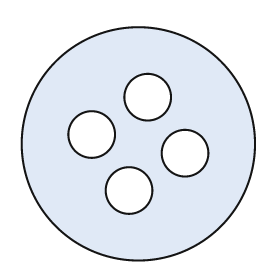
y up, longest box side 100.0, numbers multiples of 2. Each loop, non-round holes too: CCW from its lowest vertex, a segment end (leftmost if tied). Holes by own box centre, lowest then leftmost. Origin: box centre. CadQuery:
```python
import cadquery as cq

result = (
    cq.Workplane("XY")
    .moveTo(0.0, 0.0)
    .circle(50.0)
    .moveTo(-4.0, -20.0)
    .circle(10.0)
    .moveTo(20.0, -4.0)
    .circle(10.0)
    .moveTo(-20.0, 4.0)
    .circle(10.0)
    .moveTo(4.0, 20.0)
    .circle(10.0)
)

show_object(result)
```